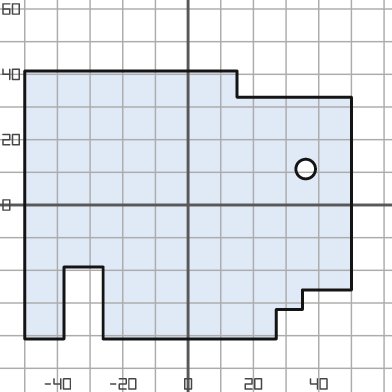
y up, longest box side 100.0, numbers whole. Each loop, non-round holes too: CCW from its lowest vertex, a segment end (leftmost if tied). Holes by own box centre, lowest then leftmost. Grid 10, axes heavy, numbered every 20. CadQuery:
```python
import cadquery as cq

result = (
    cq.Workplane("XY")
    .moveTo(-50.0, -41.0)
    .lineTo(-38.0, -41.0)
    .lineTo(-38.0, -19.0)
    .lineTo(-26.0, -19.0)
    .lineTo(-26.0, -41.0)
    .lineTo(27.0, -41.0)
    .lineTo(27.0, -32.0)
    .lineTo(35.0, -32.0)
    .lineTo(35.0, -26.0)
    .lineTo(50.0, -26.0)
    .lineTo(50.0, 33.0)
    .lineTo(15.0, 33.0)
    .lineTo(15.0, 41.0)
    .lineTo(-50.0, 41.0)
    .close()
    .moveTo(36.0, 11.0)
    .circle(3.0)
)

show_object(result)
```